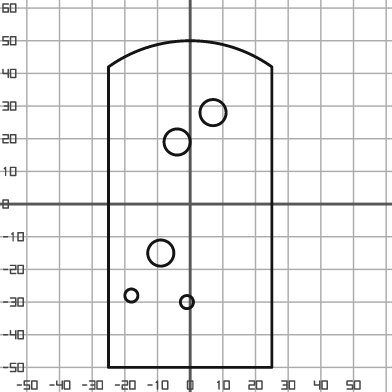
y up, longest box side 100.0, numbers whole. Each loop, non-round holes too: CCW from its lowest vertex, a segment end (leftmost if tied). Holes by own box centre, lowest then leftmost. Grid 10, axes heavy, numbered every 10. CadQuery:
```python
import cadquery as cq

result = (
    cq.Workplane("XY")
    .moveTo(-25.0, -50.0)
    .lineTo(25.0, -50.0)
    .lineTo(25.0, 42.0)
    .threePointArc((0.0, 50.0), (-25.0, 42.0))
    .close()
    .moveTo(-1.0, -30.0)
    .circle(2.0)
    .moveTo(-18.0, -28.0)
    .circle(2.0)
    .moveTo(-9.0, -15.0)
    .circle(4.0)
    .moveTo(-4.0, 19.0)
    .circle(4.0)
    .moveTo(7.0, 28.0)
    .circle(4.0)
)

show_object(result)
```